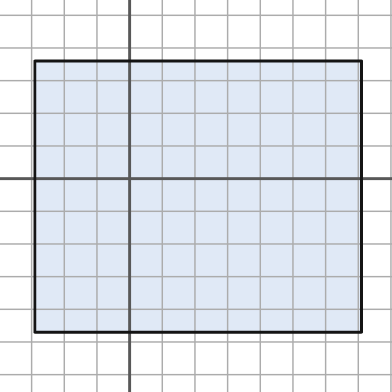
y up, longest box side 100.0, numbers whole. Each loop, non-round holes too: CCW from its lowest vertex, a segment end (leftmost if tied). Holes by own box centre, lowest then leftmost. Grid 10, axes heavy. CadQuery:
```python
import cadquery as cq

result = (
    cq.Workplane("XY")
    .moveTo(-29.0, -47.0)
    .lineTo(71.0, -47.0)
    .lineTo(71.0, 36.0)
    .lineTo(-29.0, 36.0)
    .close()
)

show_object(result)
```